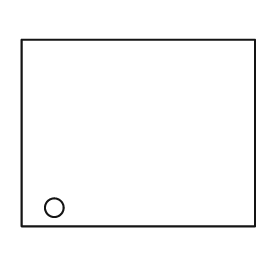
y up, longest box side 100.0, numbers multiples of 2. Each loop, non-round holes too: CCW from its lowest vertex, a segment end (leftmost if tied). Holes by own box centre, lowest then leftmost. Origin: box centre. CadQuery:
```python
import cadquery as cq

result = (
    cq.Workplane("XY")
    .moveTo(-50.0, -40.0)
    .lineTo(50.0, -40.0)
    .lineTo(50.0, 40.0)
    .lineTo(-50.0, 40.0)
    .close()
    .moveTo(-36.0, -32.0)
    .circle(4.0)
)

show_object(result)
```